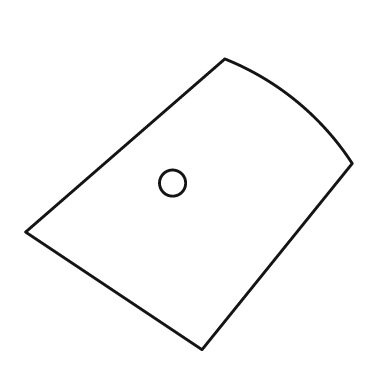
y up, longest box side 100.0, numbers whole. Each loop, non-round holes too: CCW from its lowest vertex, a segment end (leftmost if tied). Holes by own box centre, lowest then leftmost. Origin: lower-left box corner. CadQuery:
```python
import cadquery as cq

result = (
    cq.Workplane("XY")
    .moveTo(54.0, 0.0)
    .lineTo(100.0, 57.0)
    .threePointArc((83.0, 76.0), (61.0, 89.0))
    .lineTo(0.0, 36.0)
    .close()
    .moveTo(45.0, 51.0)
    .circle(4.0)
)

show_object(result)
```